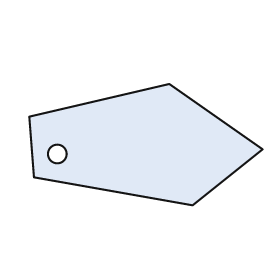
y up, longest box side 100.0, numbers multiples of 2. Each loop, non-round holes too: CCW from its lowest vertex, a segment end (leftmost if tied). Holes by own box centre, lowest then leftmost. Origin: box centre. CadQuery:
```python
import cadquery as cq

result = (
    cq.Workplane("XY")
    .moveTo(20.0, -26.0)
    .lineTo(50.0, -2.0)
    .lineTo(10.0, 26.0)
    .lineTo(-50.0, 12.0)
    .lineTo(-48.0, -14.0)
    .close()
    .moveTo(-38.0, -4.0)
    .circle(4.0)
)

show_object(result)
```